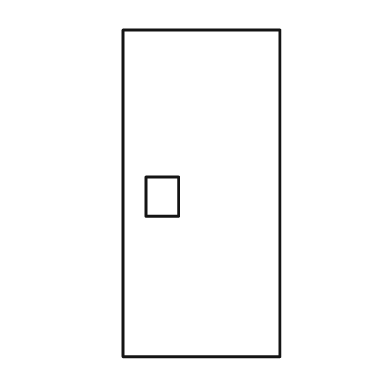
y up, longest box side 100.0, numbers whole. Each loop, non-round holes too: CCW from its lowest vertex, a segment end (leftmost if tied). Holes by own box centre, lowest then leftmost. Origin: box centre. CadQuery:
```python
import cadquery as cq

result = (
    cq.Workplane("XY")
    .moveTo(-24.0, -50.0)
    .lineTo(24.0, -50.0)
    .lineTo(24.0, 50.0)
    .lineTo(-24.0, 50.0)
    .close()
    .moveTo(-17.0, -7.0)
    .lineTo(-7.0, -7.0)
    .lineTo(-7.0, 5.0)
    .lineTo(-17.0, 5.0)
    .close()
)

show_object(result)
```